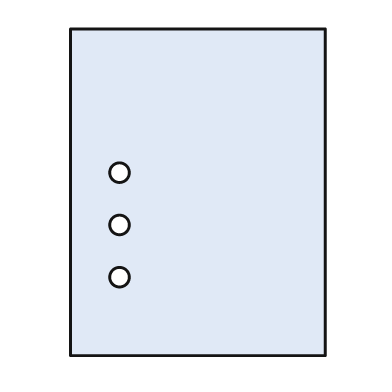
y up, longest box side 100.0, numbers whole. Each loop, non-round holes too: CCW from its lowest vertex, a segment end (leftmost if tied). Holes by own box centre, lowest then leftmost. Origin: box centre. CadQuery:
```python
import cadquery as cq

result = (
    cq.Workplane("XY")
    .moveTo(-39.0, -50.0)
    .lineTo(39.0, -50.0)
    .lineTo(39.0, 50.0)
    .lineTo(-39.0, 50.0)
    .close()
    .moveTo(-24.0, -26.0)
    .circle(3.0)
    .moveTo(-24.0, -10.0)
    .circle(3.0)
    .moveTo(-24.0, 6.0)
    .circle(3.0)
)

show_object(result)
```